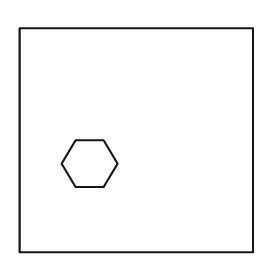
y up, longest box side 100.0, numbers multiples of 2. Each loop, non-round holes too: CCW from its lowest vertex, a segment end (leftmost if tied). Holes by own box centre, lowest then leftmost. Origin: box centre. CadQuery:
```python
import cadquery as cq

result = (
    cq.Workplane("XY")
    .moveTo(-50.0, -48.0)
    .lineTo(50.0, -48.0)
    .lineTo(50.0, 48.0)
    .lineTo(-50.0, 48.0)
    .close()
    .moveTo(-26.0, -20.0)
    .lineTo(-14.0, -20.0)
    .lineTo(-8.0, -10.0)
    .lineTo(-14.0, 0.0)
    .lineTo(-26.0, 0.0)
    .lineTo(-32.0, -10.0)
    .close()
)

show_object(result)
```